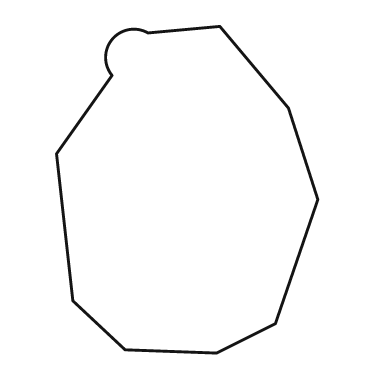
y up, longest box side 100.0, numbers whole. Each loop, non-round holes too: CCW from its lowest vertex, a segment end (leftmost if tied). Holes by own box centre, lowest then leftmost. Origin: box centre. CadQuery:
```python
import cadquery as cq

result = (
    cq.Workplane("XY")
    .moveTo(9.0, -50.0)
    .lineTo(27.0, -41.0)
    .lineTo(40.0, -3.0)
    .lineTo(31.0, 25.0)
    .lineTo(10.0, 50.0)
    .lineTo(-12.0, 48.0)
    .threePointArc((-23.0, 46.0), (-23.0, 35.0))
    .lineTo(-40.0, 11.0)
    .lineTo(-35.0, -34.0)
    .lineTo(-19.0, -49.0)
    .close()
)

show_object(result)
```